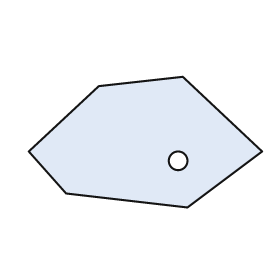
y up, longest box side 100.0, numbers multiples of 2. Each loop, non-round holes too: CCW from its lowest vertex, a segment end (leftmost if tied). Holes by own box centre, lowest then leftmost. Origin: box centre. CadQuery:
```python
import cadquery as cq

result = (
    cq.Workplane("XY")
    .moveTo(18.0, -28.0)
    .lineTo(50.0, -4.0)
    .lineTo(16.0, 28.0)
    .lineTo(-20.0, 24.0)
    .lineTo(-50.0, -4.0)
    .lineTo(-34.0, -22.0)
    .close()
    .moveTo(14.0, -8.0)
    .circle(4.0)
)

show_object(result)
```